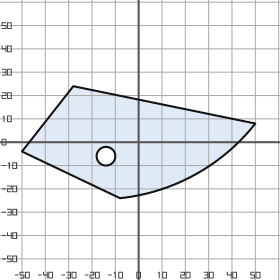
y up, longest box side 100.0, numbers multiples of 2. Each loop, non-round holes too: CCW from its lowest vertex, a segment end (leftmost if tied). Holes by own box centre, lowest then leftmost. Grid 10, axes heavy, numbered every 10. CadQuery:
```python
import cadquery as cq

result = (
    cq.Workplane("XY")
    .moveTo(-8.0, -24.0)
    .threePointArc((24.0, -14.0), (50.0, 8.0))
    .lineTo(-28.0, 24.0)
    .lineTo(-50.0, -4.0)
    .close()
    .moveTo(-14.0, -6.0)
    .circle(4.0)
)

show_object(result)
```